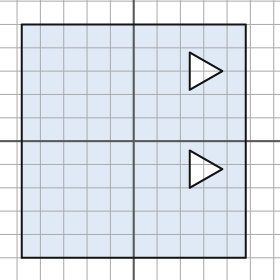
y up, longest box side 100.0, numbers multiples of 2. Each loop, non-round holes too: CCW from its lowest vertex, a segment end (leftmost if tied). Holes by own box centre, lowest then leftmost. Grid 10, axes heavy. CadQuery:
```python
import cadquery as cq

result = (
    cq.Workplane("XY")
    .moveTo(-48.0, -50.0)
    .lineTo(48.0, -50.0)
    .lineTo(48.0, 50.0)
    .lineTo(-48.0, 50.0)
    .close()
    .moveTo(24.0, -20.0)
    .lineTo(38.0, -12.0)
    .lineTo(24.0, -4.0)
    .close()
    .moveTo(24.0, 22.0)
    .lineTo(38.0, 30.0)
    .lineTo(24.0, 38.0)
    .close()
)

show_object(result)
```